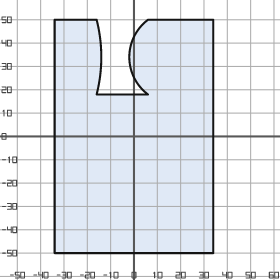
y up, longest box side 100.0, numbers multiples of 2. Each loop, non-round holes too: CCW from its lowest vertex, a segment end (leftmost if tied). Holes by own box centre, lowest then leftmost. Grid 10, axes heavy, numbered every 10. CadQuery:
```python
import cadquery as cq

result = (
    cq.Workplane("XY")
    .moveTo(-34.0, -50.0)
    .lineTo(34.0, -50.0)
    .lineTo(34.0, 50.0)
    .lineTo(6.0, 50.0)
    .threePointArc((-2.0, 34.0), (6.0, 18.0))
    .lineTo(-16.0, 18.0)
    .threePointArc((-14.0, 34.0), (-16.0, 50.0))
    .lineTo(-34.0, 50.0)
    .close()
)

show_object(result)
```